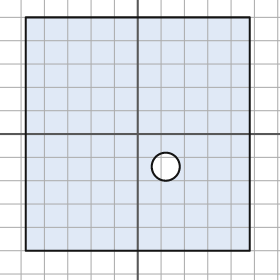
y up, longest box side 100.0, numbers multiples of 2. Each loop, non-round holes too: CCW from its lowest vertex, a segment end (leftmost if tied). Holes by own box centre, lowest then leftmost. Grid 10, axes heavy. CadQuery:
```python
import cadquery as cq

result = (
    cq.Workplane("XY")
    .moveTo(-48.0, -50.0)
    .lineTo(48.0, -50.0)
    .lineTo(48.0, 50.0)
    .lineTo(-48.0, 50.0)
    .close()
    .moveTo(12.0, -14.0)
    .circle(6.0)
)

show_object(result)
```